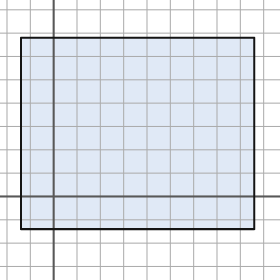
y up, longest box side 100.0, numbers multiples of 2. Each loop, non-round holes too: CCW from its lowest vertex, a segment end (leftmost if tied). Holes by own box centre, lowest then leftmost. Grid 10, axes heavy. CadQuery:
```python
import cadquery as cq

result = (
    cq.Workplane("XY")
    .moveTo(-14.0, -14.0)
    .lineTo(86.0, -14.0)
    .lineTo(86.0, 68.0)
    .lineTo(-14.0, 68.0)
    .close()
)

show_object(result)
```